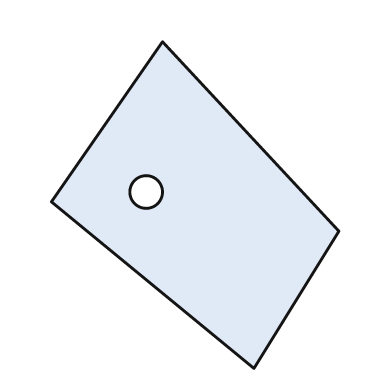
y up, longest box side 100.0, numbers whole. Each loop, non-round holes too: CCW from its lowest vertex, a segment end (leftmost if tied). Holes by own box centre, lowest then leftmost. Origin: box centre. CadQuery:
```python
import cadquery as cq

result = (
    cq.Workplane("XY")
    .moveTo(18.0, -50.0)
    .lineTo(44.0, -8.0)
    .lineTo(-10.0, 50.0)
    .lineTo(-44.0, 1.0)
    .close()
    .moveTo(-15.0, 4.0)
    .circle(5.0)
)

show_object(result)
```